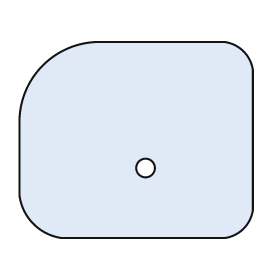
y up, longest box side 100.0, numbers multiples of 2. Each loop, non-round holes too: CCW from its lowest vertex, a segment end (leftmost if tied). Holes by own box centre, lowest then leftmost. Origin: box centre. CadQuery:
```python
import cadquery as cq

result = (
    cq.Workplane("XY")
    .moveTo(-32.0, -42.0)
    .lineTo(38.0, -42.0)
    .threePointArc((46.0, -38.0), (50.0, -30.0))
    .lineTo(50.0, 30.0)
    .threePointArc((46.0, 38.0), (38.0, 42.0))
    .lineTo(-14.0, 42.0)
    .threePointArc((-40.0, 32.0), (-50.0, 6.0))
    .lineTo(-50.0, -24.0)
    .threePointArc((-44.0, -36.0), (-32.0, -42.0))
    .close()
    .moveTo(4.0, -12.0)
    .circle(4.0)
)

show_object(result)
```